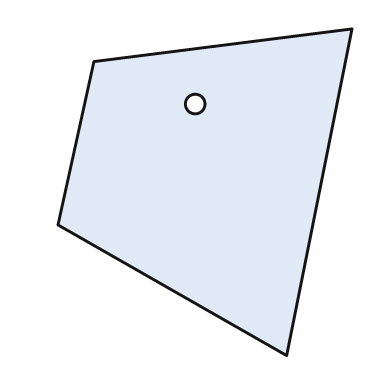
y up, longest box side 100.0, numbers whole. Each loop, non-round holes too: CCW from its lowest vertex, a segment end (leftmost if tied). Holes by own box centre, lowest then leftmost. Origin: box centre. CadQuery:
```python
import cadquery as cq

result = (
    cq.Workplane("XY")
    .moveTo(25.0, -50.0)
    .lineTo(45.0, 50.0)
    .lineTo(-34.0, 40.0)
    .lineTo(-45.0, -10.0)
    .close()
    .moveTo(-3.0, 27.0)
    .circle(3.0)
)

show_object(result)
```